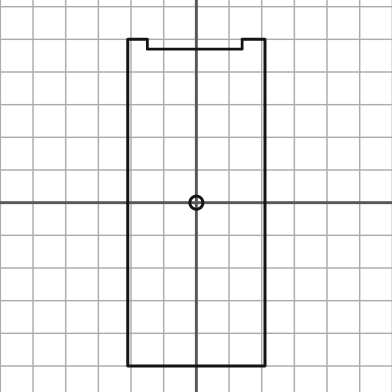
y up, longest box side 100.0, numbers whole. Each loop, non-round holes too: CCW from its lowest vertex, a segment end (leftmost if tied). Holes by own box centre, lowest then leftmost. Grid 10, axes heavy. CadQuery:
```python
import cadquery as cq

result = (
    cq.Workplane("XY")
    .moveTo(-21.0, -50.0)
    .lineTo(21.0, -50.0)
    .lineTo(21.0, 50.0)
    .lineTo(14.0, 50.0)
    .lineTo(14.0, 47.0)
    .lineTo(-15.0, 47.0)
    .lineTo(-15.0, 50.0)
    .lineTo(-21.0, 50.0)
    .close()
    .moveTo(0.0, 0.0)
    .circle(2.0)
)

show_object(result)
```